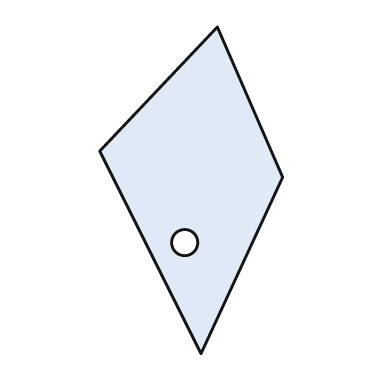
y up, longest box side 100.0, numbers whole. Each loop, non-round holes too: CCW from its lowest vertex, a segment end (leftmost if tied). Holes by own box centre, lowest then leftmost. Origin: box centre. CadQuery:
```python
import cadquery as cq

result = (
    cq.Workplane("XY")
    .moveTo(3.0, -50.0)
    .lineTo(28.0, 4.0)
    .lineTo(8.0, 50.0)
    .lineTo(-28.0, 12.0)
    .close()
    .moveTo(-2.0, -16.0)
    .circle(4.0)
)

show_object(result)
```